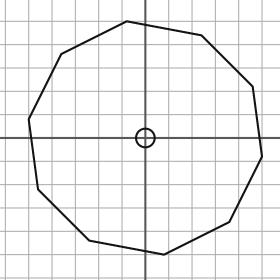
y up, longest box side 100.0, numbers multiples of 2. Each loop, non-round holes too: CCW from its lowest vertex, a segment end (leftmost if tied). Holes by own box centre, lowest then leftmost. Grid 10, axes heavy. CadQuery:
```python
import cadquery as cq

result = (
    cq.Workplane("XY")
    .moveTo(8.0, -50.0)
    .lineTo(36.0, -36.0)
    .lineTo(50.0, -8.0)
    .lineTo(46.0, 22.0)
    .lineTo(24.0, 44.0)
    .lineTo(-8.0, 50.0)
    .lineTo(-36.0, 36.0)
    .lineTo(-50.0, 8.0)
    .lineTo(-46.0, -22.0)
    .lineTo(-24.0, -44.0)
    .close()
    .moveTo(0.0, 0.0)
    .circle(4.0)
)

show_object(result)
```